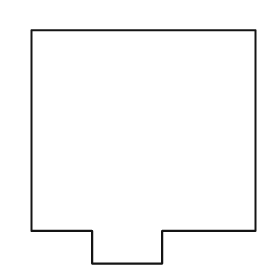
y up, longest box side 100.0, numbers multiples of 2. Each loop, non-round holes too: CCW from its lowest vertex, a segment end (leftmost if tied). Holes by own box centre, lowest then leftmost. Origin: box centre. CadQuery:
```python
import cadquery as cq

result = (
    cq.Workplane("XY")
    .moveTo(-22.0, -50.0)
    .lineTo(8.0, -50.0)
    .lineTo(8.0, -36.0)
    .lineTo(48.0, -36.0)
    .lineTo(48.0, 50.0)
    .lineTo(-48.0, 50.0)
    .lineTo(-48.0, -36.0)
    .lineTo(-22.0, -36.0)
    .close()
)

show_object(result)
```